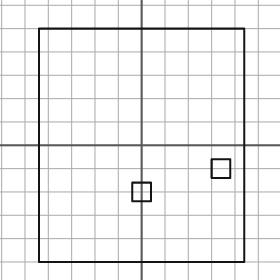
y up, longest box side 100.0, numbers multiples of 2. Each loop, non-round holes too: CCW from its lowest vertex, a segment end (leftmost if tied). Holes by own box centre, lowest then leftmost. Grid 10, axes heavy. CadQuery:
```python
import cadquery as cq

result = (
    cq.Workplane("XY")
    .moveTo(-44.0, -50.0)
    .lineTo(44.0, -50.0)
    .lineTo(44.0, 50.0)
    .lineTo(-44.0, 50.0)
    .close()
    .moveTo(-4.0, -24.0)
    .lineTo(4.0, -24.0)
    .lineTo(4.0, -16.0)
    .lineTo(-4.0, -16.0)
    .close()
    .moveTo(30.0, -14.0)
    .lineTo(38.0, -14.0)
    .lineTo(38.0, -6.0)
    .lineTo(30.0, -6.0)
    .close()
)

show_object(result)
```